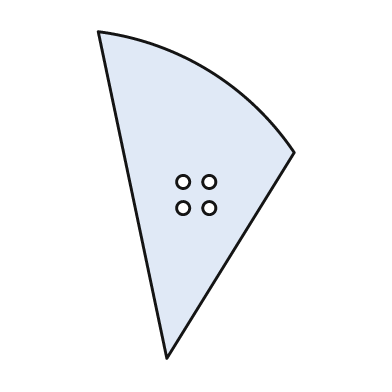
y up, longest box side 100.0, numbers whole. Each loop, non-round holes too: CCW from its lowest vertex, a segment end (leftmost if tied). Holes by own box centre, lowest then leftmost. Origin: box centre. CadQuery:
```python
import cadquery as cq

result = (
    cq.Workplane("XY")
    .moveTo(-9.0, -50.0)
    .lineTo(30.0, 13.0)
    .threePointArc((4.0, 38.0), (-30.0, 50.0))
    .close()
    .moveTo(-4.0, -4.0)
    .circle(2.0)
    .moveTo(4.0, -4.0)
    .circle(2.0)
    .moveTo(-4.0, 4.0)
    .circle(2.0)
    .moveTo(4.0, 4.0)
    .circle(2.0)
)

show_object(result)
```